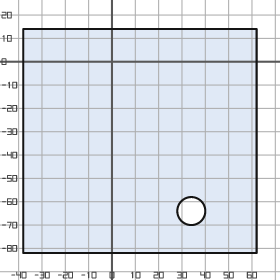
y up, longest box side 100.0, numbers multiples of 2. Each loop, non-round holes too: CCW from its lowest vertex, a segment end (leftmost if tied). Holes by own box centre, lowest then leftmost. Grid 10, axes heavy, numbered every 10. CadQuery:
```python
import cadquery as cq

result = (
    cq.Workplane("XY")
    .moveTo(-38.0, -82.0)
    .lineTo(62.0, -82.0)
    .lineTo(62.0, 14.0)
    .lineTo(-38.0, 14.0)
    .close()
    .moveTo(34.0, -64.0)
    .circle(6.0)
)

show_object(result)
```